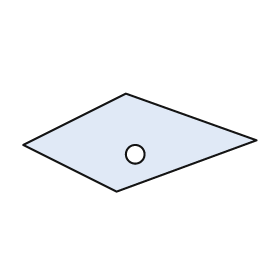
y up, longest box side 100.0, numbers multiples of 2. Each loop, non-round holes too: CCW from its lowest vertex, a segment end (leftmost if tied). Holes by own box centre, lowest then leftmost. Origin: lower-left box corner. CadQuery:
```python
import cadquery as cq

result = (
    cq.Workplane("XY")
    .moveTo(40.0, 0.0)
    .lineTo(100.0, 22.0)
    .lineTo(44.0, 42.0)
    .lineTo(0.0, 20.0)
    .close()
    .moveTo(48.0, 16.0)
    .circle(4.0)
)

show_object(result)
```